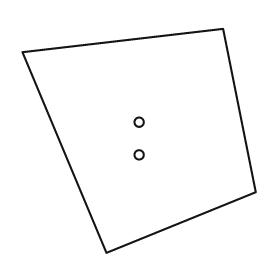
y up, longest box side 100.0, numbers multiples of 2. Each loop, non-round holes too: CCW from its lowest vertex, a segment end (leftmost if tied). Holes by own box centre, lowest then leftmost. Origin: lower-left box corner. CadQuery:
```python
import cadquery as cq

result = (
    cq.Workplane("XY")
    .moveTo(36.0, 0.0)
    .lineTo(100.0, 26.0)
    .lineTo(86.0, 96.0)
    .lineTo(0.0, 86.0)
    .close()
    .moveTo(50.0, 42.0)
    .circle(2.0)
    .moveTo(50.0, 56.0)
    .circle(2.0)
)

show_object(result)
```